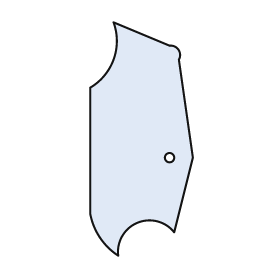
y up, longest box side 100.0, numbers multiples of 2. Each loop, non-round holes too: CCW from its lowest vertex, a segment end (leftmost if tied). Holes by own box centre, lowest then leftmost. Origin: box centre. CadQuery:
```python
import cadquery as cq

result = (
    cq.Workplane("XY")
    .moveTo(-10.0, -50.0)
    .threePointArc((-2.0, -36.0), (14.0, -40.0))
    .lineTo(22.0, -8.0)
    .lineTo(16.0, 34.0)
    .threePointArc((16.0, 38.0), (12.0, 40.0))
    .lineTo(-12.0, 50.0)
    .threePointArc((-12.0, 34.0), (-22.0, 22.0))
    .lineTo(-22.0, -32.0)
    .threePointArc((-18.0, -42.0), (-10.0, -50.0))
    .close()
    .moveTo(12.0, -8.0)
    .circle(2.0)
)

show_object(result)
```